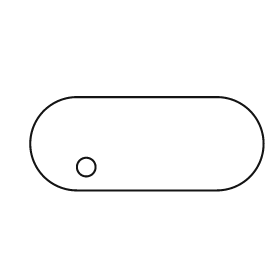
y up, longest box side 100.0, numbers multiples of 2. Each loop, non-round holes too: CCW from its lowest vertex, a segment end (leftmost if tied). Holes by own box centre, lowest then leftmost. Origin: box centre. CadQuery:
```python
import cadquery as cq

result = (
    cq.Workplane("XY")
    .moveTo(-30.0, -20.0)
    .lineTo(30.0, -20.0)
    .threePointArc((50.0, 0.0), (30.0, 20.0))
    .lineTo(-30.0, 20.0)
    .threePointArc((-50.0, 0.0), (-30.0, -20.0))
    .close()
    .moveTo(-26.0, -10.0)
    .circle(4.0)
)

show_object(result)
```